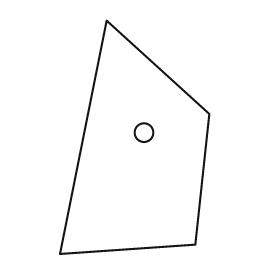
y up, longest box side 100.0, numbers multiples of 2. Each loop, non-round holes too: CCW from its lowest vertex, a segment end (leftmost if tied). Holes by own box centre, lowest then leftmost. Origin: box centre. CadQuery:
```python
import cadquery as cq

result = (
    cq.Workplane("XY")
    .moveTo(-32.0, -50.0)
    .lineTo(26.0, -46.0)
    .lineTo(32.0, 10.0)
    .lineTo(-12.0, 50.0)
    .close()
    .moveTo(4.0, 2.0)
    .circle(4.0)
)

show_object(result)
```